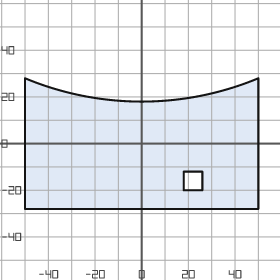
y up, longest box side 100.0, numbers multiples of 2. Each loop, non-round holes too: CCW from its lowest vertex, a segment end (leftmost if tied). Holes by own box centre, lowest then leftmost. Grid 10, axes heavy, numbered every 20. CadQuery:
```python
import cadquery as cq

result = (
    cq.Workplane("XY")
    .moveTo(-50.0, -28.0)
    .lineTo(50.0, -28.0)
    .lineTo(50.0, 28.0)
    .threePointArc((0.0, 18.0), (-50.0, 28.0))
    .close()
    .moveTo(18.0, -20.0)
    .lineTo(26.0, -20.0)
    .lineTo(26.0, -12.0)
    .lineTo(18.0, -12.0)
    .close()
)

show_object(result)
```